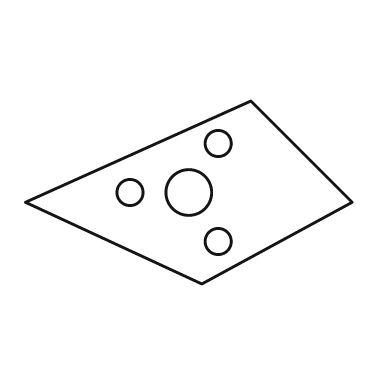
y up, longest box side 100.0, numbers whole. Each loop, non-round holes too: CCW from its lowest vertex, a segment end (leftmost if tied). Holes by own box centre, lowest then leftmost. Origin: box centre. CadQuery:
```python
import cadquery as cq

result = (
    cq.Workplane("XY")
    .moveTo(4.0, -28.0)
    .lineTo(50.0, -3.0)
    .lineTo(19.0, 28.0)
    .lineTo(-50.0, -3.0)
    .close()
    .moveTo(9.0, -15.0)
    .circle(4.0)
    .moveTo(-18.0, 0.0)
    .circle(4.0)
    .moveTo(0.0, 0.0)
    .circle(7.0)
    .moveTo(9.0, 15.0)
    .circle(4.0)
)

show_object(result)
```